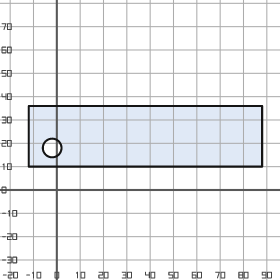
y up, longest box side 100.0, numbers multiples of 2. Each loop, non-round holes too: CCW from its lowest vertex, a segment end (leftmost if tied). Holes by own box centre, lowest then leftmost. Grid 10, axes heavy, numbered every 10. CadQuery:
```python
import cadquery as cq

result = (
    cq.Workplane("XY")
    .moveTo(-12.0, 10.0)
    .lineTo(88.0, 10.0)
    .lineTo(88.0, 36.0)
    .lineTo(-12.0, 36.0)
    .close()
    .moveTo(-2.0, 18.0)
    .circle(4.0)
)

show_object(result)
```